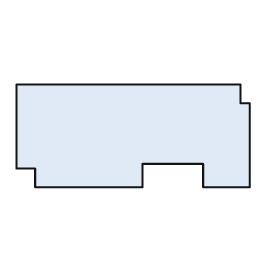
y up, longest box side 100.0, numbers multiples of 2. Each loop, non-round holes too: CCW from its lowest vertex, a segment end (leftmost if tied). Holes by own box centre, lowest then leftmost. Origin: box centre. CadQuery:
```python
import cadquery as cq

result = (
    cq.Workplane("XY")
    .moveTo(-42.0, -22.0)
    .lineTo(4.0, -22.0)
    .lineTo(4.0, -12.0)
    .lineTo(30.0, -12.0)
    .lineTo(30.0, -22.0)
    .lineTo(50.0, -22.0)
    .lineTo(50.0, 14.0)
    .lineTo(46.0, 14.0)
    .lineTo(46.0, 22.0)
    .lineTo(-50.0, 22.0)
    .lineTo(-50.0, -14.0)
    .lineTo(-42.0, -14.0)
    .close()
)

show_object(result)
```